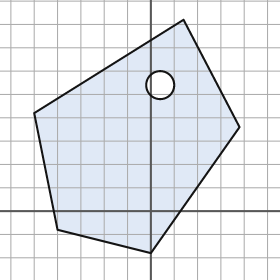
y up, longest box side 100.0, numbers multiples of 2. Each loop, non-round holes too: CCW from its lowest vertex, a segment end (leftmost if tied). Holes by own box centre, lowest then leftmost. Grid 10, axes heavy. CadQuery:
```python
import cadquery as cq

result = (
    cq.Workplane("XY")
    .moveTo(0.0, -18.0)
    .lineTo(38.0, 36.0)
    .lineTo(14.0, 82.0)
    .lineTo(-50.0, 42.0)
    .lineTo(-40.0, -8.0)
    .close()
    .moveTo(4.0, 54.0)
    .circle(6.0)
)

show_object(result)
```